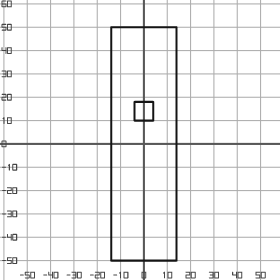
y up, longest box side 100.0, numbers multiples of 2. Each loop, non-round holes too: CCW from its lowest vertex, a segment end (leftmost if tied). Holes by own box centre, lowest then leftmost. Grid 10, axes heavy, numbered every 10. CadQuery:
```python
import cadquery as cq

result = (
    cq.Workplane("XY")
    .moveTo(-14.0, -50.0)
    .lineTo(14.0, -50.0)
    .lineTo(14.0, 50.0)
    .lineTo(-14.0, 50.0)
    .close()
    .moveTo(-4.0, 10.0)
    .lineTo(4.0, 10.0)
    .lineTo(4.0, 18.0)
    .lineTo(-4.0, 18.0)
    .close()
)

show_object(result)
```